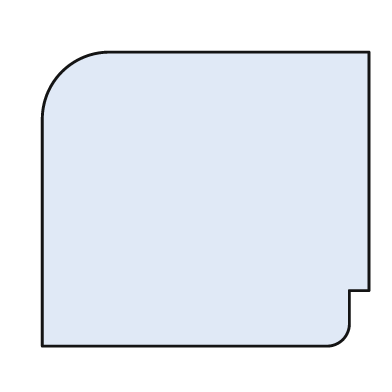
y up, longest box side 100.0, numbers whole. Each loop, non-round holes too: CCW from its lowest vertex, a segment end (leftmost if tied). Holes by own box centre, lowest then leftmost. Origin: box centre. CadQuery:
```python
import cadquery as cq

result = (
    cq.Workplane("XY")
    .moveTo(-50.0, -45.0)
    .lineTo(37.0, -45.0)
    .threePointArc((42.0, -43.0), (44.0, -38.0))
    .lineTo(44.0, -28.0)
    .lineTo(50.0, -28.0)
    .lineTo(50.0, 45.0)
    .lineTo(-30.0, 45.0)
    .threePointArc((-44.0, 39.0), (-50.0, 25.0))
    .close()
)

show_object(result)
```